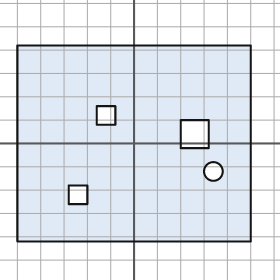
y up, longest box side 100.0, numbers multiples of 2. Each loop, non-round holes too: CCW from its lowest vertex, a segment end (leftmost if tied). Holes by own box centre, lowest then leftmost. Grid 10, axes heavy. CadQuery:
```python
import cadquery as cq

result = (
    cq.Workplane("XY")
    .moveTo(-50.0, -42.0)
    .lineTo(50.0, -42.0)
    .lineTo(50.0, 42.0)
    .lineTo(-50.0, 42.0)
    .close()
    .moveTo(-28.0, -26.0)
    .lineTo(-20.0, -26.0)
    .lineTo(-20.0, -18.0)
    .lineTo(-28.0, -18.0)
    .close()
    .moveTo(34.0, -12.0)
    .circle(4.0)
    .moveTo(20.0, -2.0)
    .lineTo(32.0, -2.0)
    .lineTo(32.0, 10.0)
    .lineTo(20.0, 10.0)
    .close()
    .moveTo(-16.0, 8.0)
    .lineTo(-8.0, 8.0)
    .lineTo(-8.0, 16.0)
    .lineTo(-16.0, 16.0)
    .close()
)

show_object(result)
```